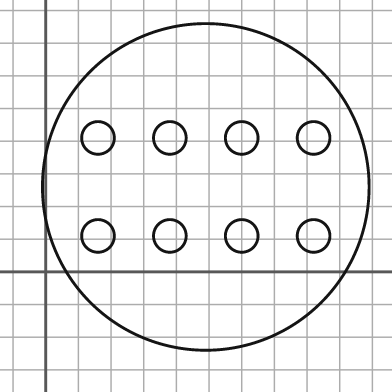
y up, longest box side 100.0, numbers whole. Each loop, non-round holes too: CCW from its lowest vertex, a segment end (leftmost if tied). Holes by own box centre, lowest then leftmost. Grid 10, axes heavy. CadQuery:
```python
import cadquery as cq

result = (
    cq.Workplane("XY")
    .moveTo(49.0, 26.0)
    .circle(50.0)
    .moveTo(16.0, 11.0)
    .circle(5.0)
    .moveTo(38.0, 11.0)
    .circle(5.0)
    .moveTo(60.0, 11.0)
    .circle(5.0)
    .moveTo(82.0, 11.0)
    .circle(5.0)
    .moveTo(16.0, 41.0)
    .circle(5.0)
    .moveTo(38.0, 41.0)
    .circle(5.0)
    .moveTo(60.0, 41.0)
    .circle(5.0)
    .moveTo(82.0, 41.0)
    .circle(5.0)
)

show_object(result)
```